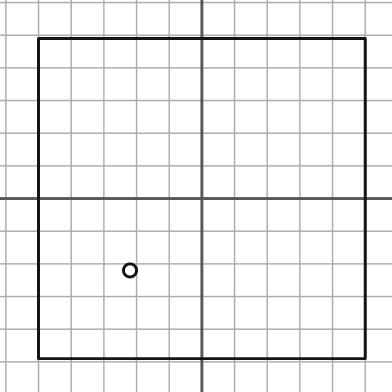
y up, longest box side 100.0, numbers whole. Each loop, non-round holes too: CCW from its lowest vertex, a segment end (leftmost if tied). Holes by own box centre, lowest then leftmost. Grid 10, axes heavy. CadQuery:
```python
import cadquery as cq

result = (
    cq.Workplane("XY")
    .moveTo(-50.0, -49.0)
    .lineTo(50.0, -49.0)
    .lineTo(50.0, 49.0)
    .lineTo(-50.0, 49.0)
    .close()
    .moveTo(-22.0, -22.0)
    .circle(2.0)
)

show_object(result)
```